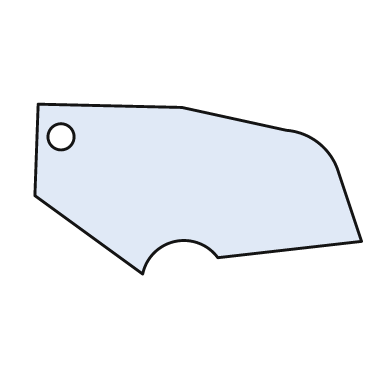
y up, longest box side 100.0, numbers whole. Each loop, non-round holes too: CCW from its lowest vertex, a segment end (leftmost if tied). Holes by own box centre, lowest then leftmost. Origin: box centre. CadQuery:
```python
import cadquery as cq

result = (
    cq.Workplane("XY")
    .moveTo(-17.0, -26.0)
    .threePointArc((-7.0, -16.0), (6.0, -21.0))
    .lineTo(50.0, -16.0)
    .lineTo(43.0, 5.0)
    .threePointArc((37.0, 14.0), (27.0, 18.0))
    .lineTo(-5.0, 25.0)
    .lineTo(-49.0, 26.0)
    .lineTo(-50.0, -2.0)
    .close()
    .moveTo(-42.0, 16.0)
    .circle(4.0)
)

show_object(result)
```